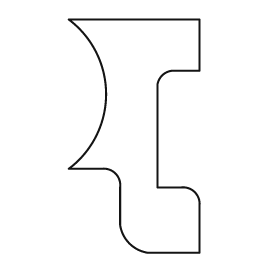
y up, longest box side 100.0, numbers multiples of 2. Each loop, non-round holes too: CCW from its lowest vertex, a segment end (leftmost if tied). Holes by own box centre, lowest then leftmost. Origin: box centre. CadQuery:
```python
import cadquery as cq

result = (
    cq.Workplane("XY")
    .moveTo(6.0, -50.0)
    .lineTo(28.0, -50.0)
    .lineTo(28.0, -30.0)
    .threePointArc((26.0, -24.0), (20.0, -22.0))
    .lineTo(10.0, -22.0)
    .lineTo(10.0, 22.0)
    .threePointArc((12.0, 26.0), (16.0, 28.0))
    .lineTo(28.0, 28.0)
    .lineTo(28.0, 50.0)
    .lineTo(-28.0, 50.0)
    .threePointArc((-12.0, 18.0), (-28.0, -14.0))
    .lineTo(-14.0, -14.0)
    .threePointArc((-8.0, -16.0), (-6.0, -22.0))
    .lineTo(-6.0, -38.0)
    .threePointArc((-2.0, -46.0), (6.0, -50.0))
    .close()
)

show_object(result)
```